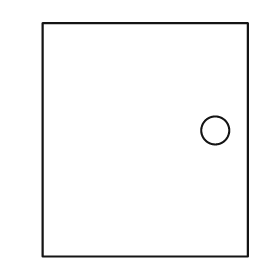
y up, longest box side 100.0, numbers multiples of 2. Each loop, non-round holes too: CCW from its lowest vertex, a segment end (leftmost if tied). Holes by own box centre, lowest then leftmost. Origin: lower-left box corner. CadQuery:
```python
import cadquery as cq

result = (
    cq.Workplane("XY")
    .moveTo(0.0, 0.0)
    .lineTo(88.0, 0.0)
    .lineTo(88.0, 100.0)
    .lineTo(0.0, 100.0)
    .close()
    .moveTo(74.0, 54.0)
    .circle(6.0)
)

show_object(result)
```